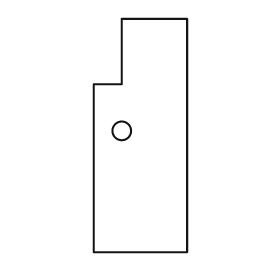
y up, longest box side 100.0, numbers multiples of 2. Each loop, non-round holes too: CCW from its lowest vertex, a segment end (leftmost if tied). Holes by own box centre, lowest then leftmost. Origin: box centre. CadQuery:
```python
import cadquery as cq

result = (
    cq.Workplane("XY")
    .moveTo(-20.0, -50.0)
    .lineTo(20.0, -50.0)
    .lineTo(20.0, 50.0)
    .lineTo(-8.0, 50.0)
    .lineTo(-8.0, 22.0)
    .lineTo(-20.0, 22.0)
    .close()
    .moveTo(-8.0, 2.0)
    .circle(4.0)
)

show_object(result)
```